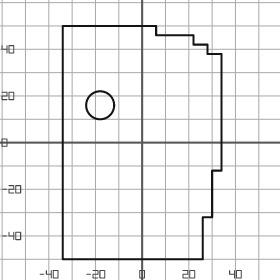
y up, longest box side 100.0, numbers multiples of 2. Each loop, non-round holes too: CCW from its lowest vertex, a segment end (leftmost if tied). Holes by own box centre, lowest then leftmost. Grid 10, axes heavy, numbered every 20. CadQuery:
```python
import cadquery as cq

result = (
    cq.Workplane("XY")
    .moveTo(-34.0, -50.0)
    .lineTo(26.0, -50.0)
    .lineTo(26.0, -32.0)
    .lineTo(30.0, -32.0)
    .lineTo(30.0, -12.0)
    .lineTo(34.0, -12.0)
    .lineTo(34.0, 38.0)
    .lineTo(28.0, 38.0)
    .lineTo(28.0, 42.0)
    .lineTo(22.0, 42.0)
    .lineTo(22.0, 46.0)
    .lineTo(6.0, 46.0)
    .lineTo(6.0, 50.0)
    .lineTo(-34.0, 50.0)
    .close()
    .moveTo(-18.0, 16.0)
    .circle(6.0)
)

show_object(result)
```